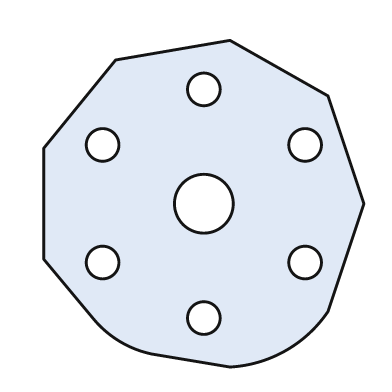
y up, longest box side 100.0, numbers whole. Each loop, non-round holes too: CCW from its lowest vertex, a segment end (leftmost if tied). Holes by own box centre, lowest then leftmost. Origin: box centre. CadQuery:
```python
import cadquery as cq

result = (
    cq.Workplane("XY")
    .moveTo(8.0, -50.0)
    .threePointArc((25.0, -45.0), (38.0, -33.0))
    .lineTo(49.0, 0.0)
    .lineTo(38.0, 33.0)
    .lineTo(8.0, 50.0)
    .lineTo(-27.0, 44.0)
    .lineTo(-49.0, 17.0)
    .lineTo(-49.0, -17.0)
    .lineTo(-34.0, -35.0)
    .threePointArc((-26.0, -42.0), (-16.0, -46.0))
    .close()
    .moveTo(0.0, -35.0)
    .circle(5.0)
    .moveTo(-31.0, -18.0)
    .circle(5.0)
    .moveTo(31.0, -18.0)
    .circle(5.0)
    .moveTo(0.0, 0.0)
    .circle(9.0)
    .moveTo(-31.0, 18.0)
    .circle(5.0)
    .moveTo(31.0, 18.0)
    .circle(5.0)
    .moveTo(0.0, 35.0)
    .circle(5.0)
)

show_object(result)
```